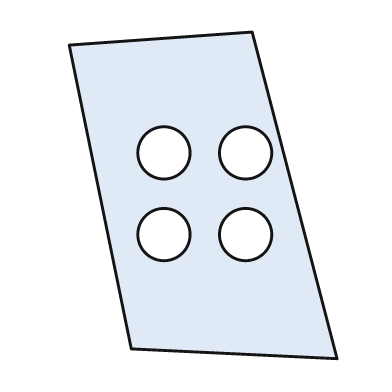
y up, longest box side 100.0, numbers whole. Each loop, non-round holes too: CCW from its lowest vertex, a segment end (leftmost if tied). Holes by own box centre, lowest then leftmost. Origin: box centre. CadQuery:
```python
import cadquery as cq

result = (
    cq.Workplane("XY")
    .moveTo(41.0, -50.0)
    .lineTo(15.0, 50.0)
    .lineTo(-41.0, 46.0)
    .lineTo(-22.0, -47.0)
    .close()
    .moveTo(-12.0, -12.0)
    .circle(8.0)
    .moveTo(13.0, -12.0)
    .circle(8.0)
    .moveTo(-12.0, 13.0)
    .circle(8.0)
    .moveTo(13.0, 13.0)
    .circle(8.0)
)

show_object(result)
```